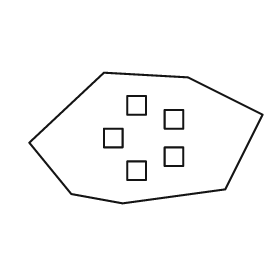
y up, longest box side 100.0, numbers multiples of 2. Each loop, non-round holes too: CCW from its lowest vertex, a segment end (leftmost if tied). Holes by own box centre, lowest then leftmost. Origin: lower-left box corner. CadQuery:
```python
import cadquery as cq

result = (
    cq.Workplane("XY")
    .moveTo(40.0, 0.0)
    .lineTo(84.0, 6.0)
    .lineTo(100.0, 38.0)
    .lineTo(68.0, 54.0)
    .lineTo(32.0, 56.0)
    .lineTo(0.0, 26.0)
    .lineTo(18.0, 4.0)
    .close()
    .moveTo(42.0, 10.0)
    .lineTo(50.0, 10.0)
    .lineTo(50.0, 18.0)
    .lineTo(42.0, 18.0)
    .close()
    .moveTo(58.0, 16.0)
    .lineTo(66.0, 16.0)
    .lineTo(66.0, 24.0)
    .lineTo(58.0, 24.0)
    .close()
    .moveTo(32.0, 24.0)
    .lineTo(40.0, 24.0)
    .lineTo(40.0, 32.0)
    .lineTo(32.0, 32.0)
    .close()
    .moveTo(58.0, 32.0)
    .lineTo(66.0, 32.0)
    .lineTo(66.0, 40.0)
    .lineTo(58.0, 40.0)
    .close()
    .moveTo(42.0, 38.0)
    .lineTo(50.0, 38.0)
    .lineTo(50.0, 46.0)
    .lineTo(42.0, 46.0)
    .close()
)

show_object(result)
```